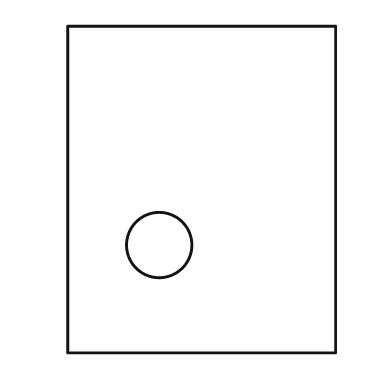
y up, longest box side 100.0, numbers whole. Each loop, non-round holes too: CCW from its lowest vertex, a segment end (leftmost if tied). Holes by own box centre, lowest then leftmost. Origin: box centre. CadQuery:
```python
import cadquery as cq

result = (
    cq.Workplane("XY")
    .moveTo(-41.0, -50.0)
    .lineTo(41.0, -50.0)
    .lineTo(41.0, 50.0)
    .lineTo(-41.0, 50.0)
    .close()
    .moveTo(-13.0, -17.0)
    .circle(10.0)
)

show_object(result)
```